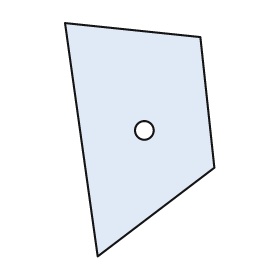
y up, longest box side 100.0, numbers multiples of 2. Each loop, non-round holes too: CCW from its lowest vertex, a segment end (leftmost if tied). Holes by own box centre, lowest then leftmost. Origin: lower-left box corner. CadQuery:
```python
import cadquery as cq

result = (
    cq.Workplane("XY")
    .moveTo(14.0, 0.0)
    .lineTo(64.0, 38.0)
    .lineTo(58.0, 94.0)
    .lineTo(0.0, 100.0)
    .close()
    .moveTo(34.0, 54.0)
    .circle(4.0)
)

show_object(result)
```